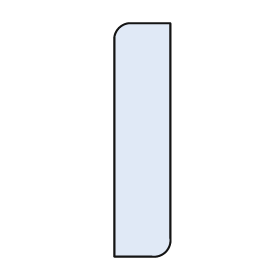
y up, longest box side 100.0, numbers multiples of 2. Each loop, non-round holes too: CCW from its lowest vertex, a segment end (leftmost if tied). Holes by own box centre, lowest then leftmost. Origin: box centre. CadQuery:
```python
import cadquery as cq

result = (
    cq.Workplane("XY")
    .moveTo(-12.0, -50.0)
    .lineTo(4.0, -50.0)
    .threePointArc((10.0, -48.0), (12.0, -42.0))
    .lineTo(12.0, 50.0)
    .lineTo(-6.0, 50.0)
    .threePointArc((-10.0, 48.0), (-12.0, 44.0))
    .close()
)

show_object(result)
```